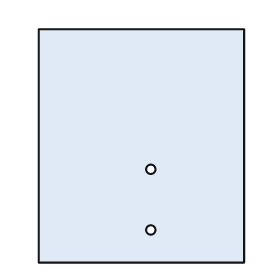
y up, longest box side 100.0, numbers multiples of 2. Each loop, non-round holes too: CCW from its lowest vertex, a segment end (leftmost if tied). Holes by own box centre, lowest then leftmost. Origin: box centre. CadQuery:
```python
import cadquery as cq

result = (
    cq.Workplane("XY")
    .moveTo(-44.0, -50.0)
    .lineTo(44.0, -50.0)
    .lineTo(44.0, 50.0)
    .lineTo(-44.0, 50.0)
    .close()
    .moveTo(4.0, -36.0)
    .circle(2.0)
    .moveTo(4.0, -10.0)
    .circle(2.0)
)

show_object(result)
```